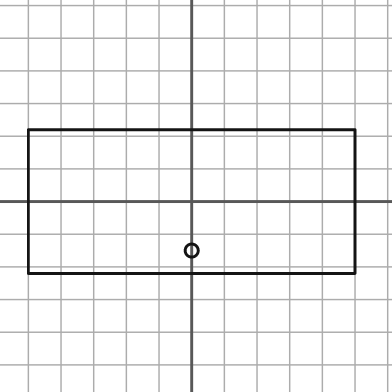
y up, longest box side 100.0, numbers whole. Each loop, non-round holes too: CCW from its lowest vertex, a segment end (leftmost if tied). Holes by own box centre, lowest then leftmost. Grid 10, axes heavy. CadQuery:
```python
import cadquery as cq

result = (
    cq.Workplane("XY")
    .moveTo(-50.0, -22.0)
    .lineTo(50.0, -22.0)
    .lineTo(50.0, 22.0)
    .lineTo(-50.0, 22.0)
    .close()
    .moveTo(0.0, -15.0)
    .circle(2.0)
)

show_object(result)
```